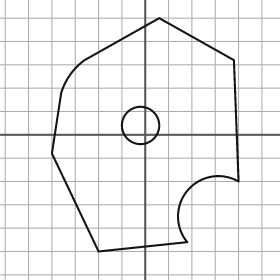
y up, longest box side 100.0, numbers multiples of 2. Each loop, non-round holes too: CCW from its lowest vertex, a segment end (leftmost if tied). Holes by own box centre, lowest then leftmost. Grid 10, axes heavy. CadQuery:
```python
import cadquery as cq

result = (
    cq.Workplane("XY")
    .moveTo(-20.0, -50.0)
    .lineTo(18.0, -46.0)
    .threePointArc((18.0, -24.0), (40.0, -20.0))
    .lineTo(38.0, 32.0)
    .lineTo(6.0, 50.0)
    .lineTo(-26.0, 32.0)
    .threePointArc((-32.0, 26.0), (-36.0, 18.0))
    .lineTo(-40.0, -8.0)
    .close()
    .moveTo(-2.0, 4.0)
    .circle(8.0)
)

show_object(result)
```